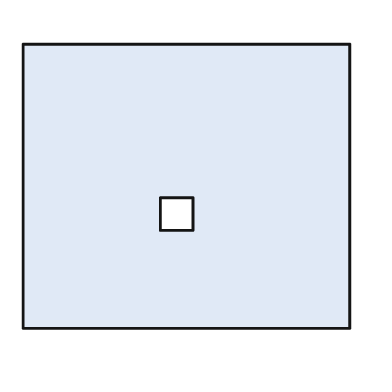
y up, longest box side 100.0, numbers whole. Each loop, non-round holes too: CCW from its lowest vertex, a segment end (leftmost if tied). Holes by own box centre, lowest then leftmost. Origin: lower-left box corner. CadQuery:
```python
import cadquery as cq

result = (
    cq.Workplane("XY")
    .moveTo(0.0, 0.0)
    .lineTo(100.0, 0.0)
    .lineTo(100.0, 87.0)
    .lineTo(0.0, 87.0)
    .close()
    .moveTo(42.0, 30.0)
    .lineTo(52.0, 30.0)
    .lineTo(52.0, 40.0)
    .lineTo(42.0, 40.0)
    .close()
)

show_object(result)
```